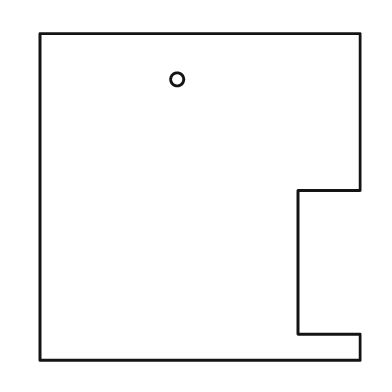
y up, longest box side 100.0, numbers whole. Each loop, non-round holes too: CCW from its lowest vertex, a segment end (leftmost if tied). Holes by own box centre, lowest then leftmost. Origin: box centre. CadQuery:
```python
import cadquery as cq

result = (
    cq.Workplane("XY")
    .moveTo(-49.0, -50.0)
    .lineTo(49.0, -50.0)
    .lineTo(49.0, -42.0)
    .lineTo(30.0, -42.0)
    .lineTo(30.0, 2.0)
    .lineTo(49.0, 2.0)
    .lineTo(49.0, 50.0)
    .lineTo(-49.0, 50.0)
    .close()
    .moveTo(-7.0, 36.0)
    .circle(2.0)
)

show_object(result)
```